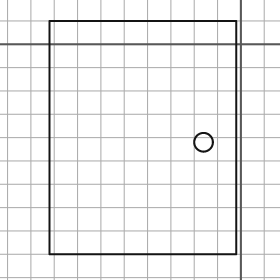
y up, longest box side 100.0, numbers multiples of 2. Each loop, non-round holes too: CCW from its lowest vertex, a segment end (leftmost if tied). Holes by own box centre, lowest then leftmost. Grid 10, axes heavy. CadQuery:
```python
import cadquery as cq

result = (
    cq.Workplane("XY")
    .moveTo(-82.0, -90.0)
    .lineTo(-2.0, -90.0)
    .lineTo(-2.0, 10.0)
    .lineTo(-82.0, 10.0)
    .close()
    .moveTo(-16.0, -42.0)
    .circle(4.0)
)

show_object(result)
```